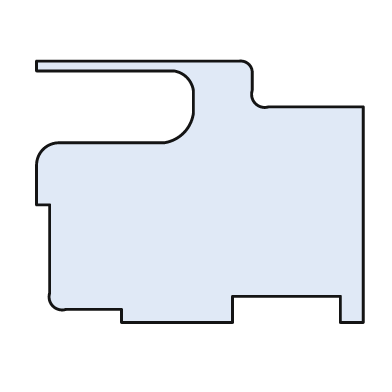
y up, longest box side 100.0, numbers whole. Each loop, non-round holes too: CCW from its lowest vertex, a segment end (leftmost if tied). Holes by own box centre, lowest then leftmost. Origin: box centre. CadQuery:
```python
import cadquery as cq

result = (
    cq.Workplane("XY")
    .moveTo(-24.0, -40.0)
    .lineTo(10.0, -40.0)
    .lineTo(10.0, -32.0)
    .lineTo(43.0, -32.0)
    .lineTo(43.0, -40.0)
    .lineTo(50.0, -40.0)
    .lineTo(50.0, 26.0)
    .lineTo(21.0, 26.0)
    .threePointArc((17.0, 27.0), (16.0, 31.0))
    .lineTo(16.0, 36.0)
    .threePointArc((15.0, 39.0), (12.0, 40.0))
    .lineTo(-50.0, 40.0)
    .lineTo(-50.0, 37.0)
    .lineTo(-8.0, 37.0)
    .threePointArc((-4.0, 35.0), (-2.0, 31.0))
    .lineTo(-2.0, 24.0)
    .threePointArc((-5.0, 18.0), (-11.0, 15.0))
    .lineTo(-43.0, 15.0)
    .threePointArc((-48.0, 13.0), (-50.0, 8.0))
    .lineTo(-50.0, -4.0)
    .lineTo(-46.0, -4.0)
    .lineTo(-46.0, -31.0)
    .threePointArc((-45.0, -35.0), (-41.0, -36.0))
    .lineTo(-24.0, -36.0)
    .close()
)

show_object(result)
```